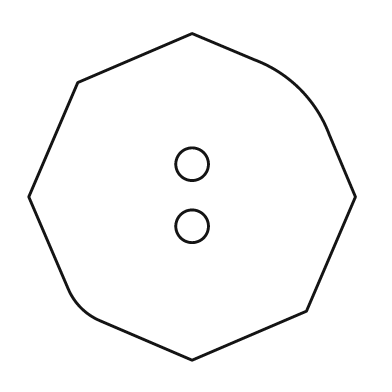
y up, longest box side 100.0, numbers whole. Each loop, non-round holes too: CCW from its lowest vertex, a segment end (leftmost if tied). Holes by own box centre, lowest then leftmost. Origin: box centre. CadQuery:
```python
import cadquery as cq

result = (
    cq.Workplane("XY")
    .moveTo(0.0, -50.0)
    .lineTo(35.0, -35.0)
    .lineTo(50.0, 0.0)
    .lineTo(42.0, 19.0)
    .threePointArc((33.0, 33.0), (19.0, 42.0))
    .lineTo(0.0, 50.0)
    .lineTo(-35.0, 35.0)
    .lineTo(-50.0, 0.0)
    .lineTo(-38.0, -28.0)
    .threePointArc((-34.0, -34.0), (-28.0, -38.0))
    .close()
    .moveTo(0.0, -9.0)
    .circle(5.0)
    .moveTo(0.0, 10.0)
    .circle(5.0)
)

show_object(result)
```